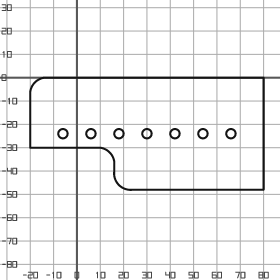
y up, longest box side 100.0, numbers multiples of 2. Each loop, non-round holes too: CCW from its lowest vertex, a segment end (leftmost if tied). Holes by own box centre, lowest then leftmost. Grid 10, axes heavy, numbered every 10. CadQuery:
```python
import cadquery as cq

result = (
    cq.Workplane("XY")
    .moveTo(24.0, -48.0)
    .lineTo(80.0, -48.0)
    .lineTo(80.0, 0.0)
    .lineTo(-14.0, 0.0)
    .threePointArc((-18.0, -2.0), (-20.0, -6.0))
    .lineTo(-20.0, -30.0)
    .lineTo(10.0, -30.0)
    .threePointArc((14.0, -32.0), (16.0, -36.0))
    .lineTo(16.0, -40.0)
    .threePointArc((18.0, -46.0), (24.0, -48.0))
    .close()
    .moveTo(-6.0, -24.0)
    .circle(2.0)
    .moveTo(6.0, -24.0)
    .circle(2.0)
    .moveTo(18.0, -24.0)
    .circle(2.0)
    .moveTo(30.0, -24.0)
    .circle(2.0)
    .moveTo(42.0, -24.0)
    .circle(2.0)
    .moveTo(54.0, -24.0)
    .circle(2.0)
    .moveTo(66.0, -24.0)
    .circle(2.0)
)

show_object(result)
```